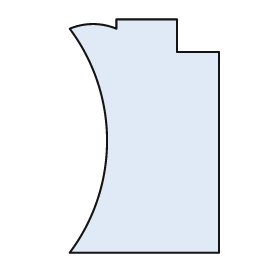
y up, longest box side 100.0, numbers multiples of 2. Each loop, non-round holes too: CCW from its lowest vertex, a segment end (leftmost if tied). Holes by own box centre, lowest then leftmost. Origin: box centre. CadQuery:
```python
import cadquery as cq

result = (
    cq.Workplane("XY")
    .moveTo(-32.0, -50.0)
    .lineTo(32.0, -50.0)
    .lineTo(32.0, 36.0)
    .lineTo(14.0, 36.0)
    .lineTo(14.0, 50.0)
    .lineTo(-12.0, 50.0)
    .lineTo(-12.0, 46.0)
    .threePointArc((-22.0, 48.0), (-32.0, 46.0))
    .threePointArc((-16.0, -2.0), (-32.0, -50.0))
    .close()
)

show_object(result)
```